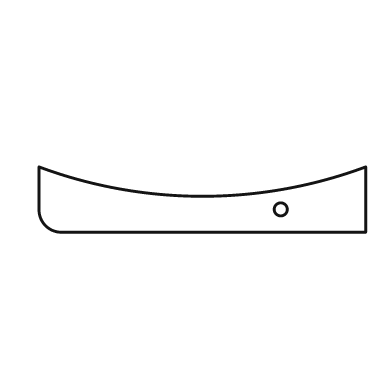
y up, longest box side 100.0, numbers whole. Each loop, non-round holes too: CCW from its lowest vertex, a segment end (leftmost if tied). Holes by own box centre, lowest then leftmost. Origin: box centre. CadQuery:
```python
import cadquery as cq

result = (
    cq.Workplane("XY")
    .moveTo(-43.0, -10.0)
    .lineTo(50.0, -10.0)
    .lineTo(50.0, 10.0)
    .threePointArc((0.0, 1.0), (-50.0, 10.0))
    .lineTo(-50.0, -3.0)
    .threePointArc((-48.0, -8.0), (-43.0, -10.0))
    .close()
    .moveTo(24.0, -3.0)
    .circle(2.0)
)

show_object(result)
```